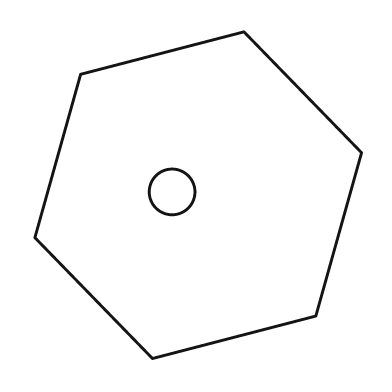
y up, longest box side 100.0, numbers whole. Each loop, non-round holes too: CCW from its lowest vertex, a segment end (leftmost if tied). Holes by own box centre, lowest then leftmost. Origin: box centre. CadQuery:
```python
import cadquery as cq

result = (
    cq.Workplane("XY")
    .moveTo(-14.0, -50.0)
    .lineTo(36.0, -37.0)
    .lineTo(50.0, 13.0)
    .lineTo(14.0, 50.0)
    .lineTo(-36.0, 37.0)
    .lineTo(-50.0, -13.0)
    .close()
    .moveTo(-8.0, 1.0)
    .circle(7.0)
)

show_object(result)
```